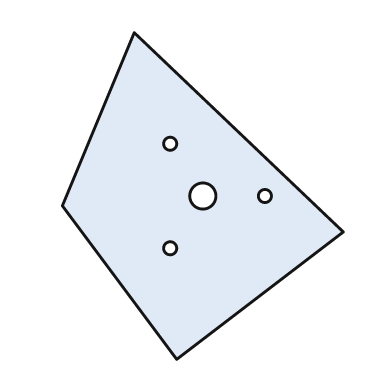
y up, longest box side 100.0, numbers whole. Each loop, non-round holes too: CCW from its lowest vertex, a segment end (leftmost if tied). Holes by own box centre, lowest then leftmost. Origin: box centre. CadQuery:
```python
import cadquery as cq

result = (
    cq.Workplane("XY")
    .moveTo(-8.0, -50.0)
    .lineTo(43.0, -11.0)
    .lineTo(-21.0, 50.0)
    .lineTo(-43.0, -3.0)
    .close()
    .moveTo(-10.0, -16.0)
    .circle(2.0)
    .moveTo(0.0, 0.0)
    .circle(4.0)
    .moveTo(19.0, 0.0)
    .circle(2.0)
    .moveTo(-10.0, 16.0)
    .circle(2.0)
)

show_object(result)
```